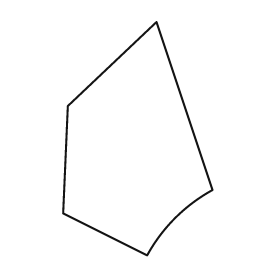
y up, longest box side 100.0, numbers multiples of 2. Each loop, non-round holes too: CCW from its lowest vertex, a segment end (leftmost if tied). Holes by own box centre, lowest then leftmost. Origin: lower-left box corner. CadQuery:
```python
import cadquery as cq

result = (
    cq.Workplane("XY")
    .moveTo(36.0, 0.0)
    .threePointArc((48.0, 16.0), (64.0, 28.0))
    .lineTo(40.0, 100.0)
    .lineTo(2.0, 64.0)
    .lineTo(0.0, 18.0)
    .close()
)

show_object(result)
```